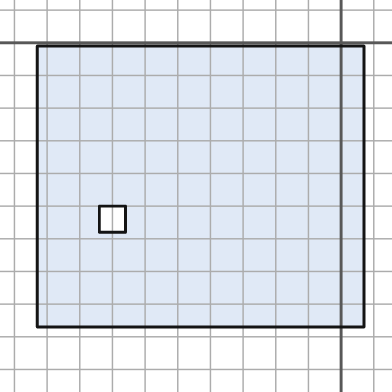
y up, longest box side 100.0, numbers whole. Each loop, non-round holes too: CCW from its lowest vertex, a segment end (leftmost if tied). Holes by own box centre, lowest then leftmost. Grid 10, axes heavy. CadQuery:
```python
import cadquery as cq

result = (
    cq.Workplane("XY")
    .moveTo(-93.0, -87.0)
    .lineTo(7.0, -87.0)
    .lineTo(7.0, -1.0)
    .lineTo(-93.0, -1.0)
    .close()
    .moveTo(-74.0, -58.0)
    .lineTo(-66.0, -58.0)
    .lineTo(-66.0, -50.0)
    .lineTo(-74.0, -50.0)
    .close()
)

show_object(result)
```